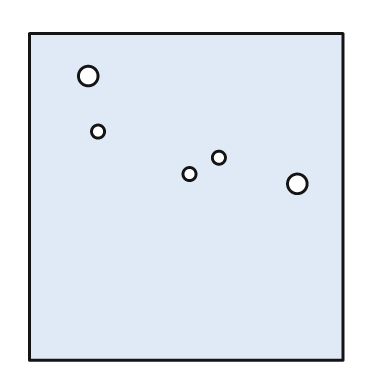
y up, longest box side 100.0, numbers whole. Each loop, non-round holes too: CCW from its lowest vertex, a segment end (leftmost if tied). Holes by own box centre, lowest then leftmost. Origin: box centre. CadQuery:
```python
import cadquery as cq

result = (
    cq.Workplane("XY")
    .moveTo(-48.0, -50.0)
    .lineTo(48.0, -50.0)
    .lineTo(48.0, 50.0)
    .lineTo(-48.0, 50.0)
    .close()
    .moveTo(34.0, 4.0)
    .circle(3.0)
    .moveTo(1.0, 7.0)
    .circle(2.0)
    .moveTo(10.0, 12.0)
    .circle(2.0)
    .moveTo(-27.0, 20.0)
    .circle(2.0)
    .moveTo(-30.0, 37.0)
    .circle(3.0)
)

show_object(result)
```